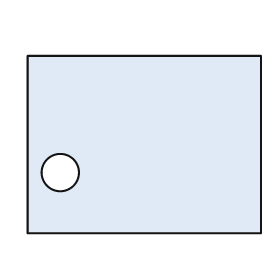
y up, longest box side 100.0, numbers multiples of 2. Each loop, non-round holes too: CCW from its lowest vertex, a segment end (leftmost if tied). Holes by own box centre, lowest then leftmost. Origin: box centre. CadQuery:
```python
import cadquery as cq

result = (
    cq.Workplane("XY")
    .moveTo(-50.0, -38.0)
    .lineTo(50.0, -38.0)
    .lineTo(50.0, 38.0)
    .lineTo(-50.0, 38.0)
    .close()
    .moveTo(-36.0, -12.0)
    .circle(8.0)
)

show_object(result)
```